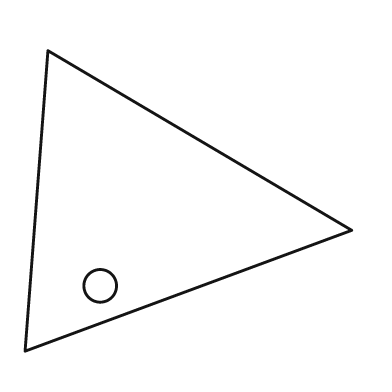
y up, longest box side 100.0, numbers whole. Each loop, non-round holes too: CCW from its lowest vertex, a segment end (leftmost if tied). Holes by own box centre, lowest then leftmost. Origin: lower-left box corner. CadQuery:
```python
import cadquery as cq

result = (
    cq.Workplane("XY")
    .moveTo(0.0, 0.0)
    .lineTo(100.0, 37.0)
    .lineTo(7.0, 92.0)
    .close()
    .moveTo(23.0, 20.0)
    .circle(5.0)
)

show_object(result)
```